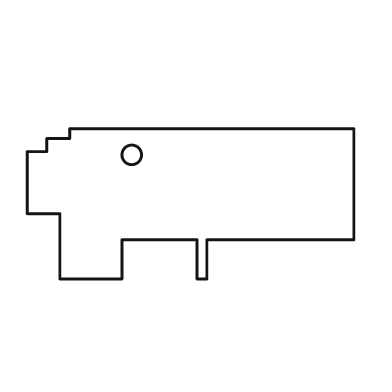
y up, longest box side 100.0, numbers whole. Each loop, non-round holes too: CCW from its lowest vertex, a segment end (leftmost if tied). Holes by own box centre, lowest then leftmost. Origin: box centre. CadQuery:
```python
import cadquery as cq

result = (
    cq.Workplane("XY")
    .moveTo(-40.0, -23.0)
    .lineTo(-21.0, -23.0)
    .lineTo(-21.0, -11.0)
    .lineTo(2.0, -11.0)
    .lineTo(2.0, -23.0)
    .lineTo(5.0, -23.0)
    .lineTo(5.0, -11.0)
    .lineTo(50.0, -11.0)
    .lineTo(50.0, 23.0)
    .lineTo(-37.0, 23.0)
    .lineTo(-37.0, 20.0)
    .lineTo(-44.0, 20.0)
    .lineTo(-44.0, 16.0)
    .lineTo(-50.0, 16.0)
    .lineTo(-50.0, -3.0)
    .lineTo(-40.0, -3.0)
    .close()
    .moveTo(-18.0, 15.0)
    .circle(3.0)
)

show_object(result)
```